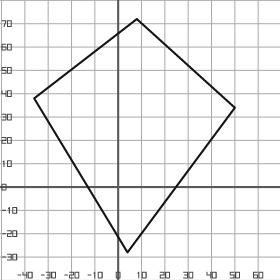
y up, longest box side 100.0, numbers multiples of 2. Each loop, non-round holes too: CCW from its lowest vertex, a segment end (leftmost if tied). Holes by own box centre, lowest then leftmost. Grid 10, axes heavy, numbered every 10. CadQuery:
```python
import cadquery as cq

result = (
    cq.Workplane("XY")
    .moveTo(4.0, -28.0)
    .lineTo(50.0, 34.0)
    .lineTo(8.0, 72.0)
    .lineTo(-36.0, 38.0)
    .close()
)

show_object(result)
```